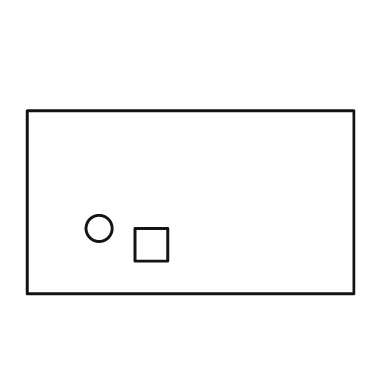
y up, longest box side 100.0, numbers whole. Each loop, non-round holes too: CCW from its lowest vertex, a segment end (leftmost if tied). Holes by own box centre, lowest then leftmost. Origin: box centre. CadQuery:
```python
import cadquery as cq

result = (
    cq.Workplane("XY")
    .moveTo(-50.0, -28.0)
    .lineTo(50.0, -28.0)
    .lineTo(50.0, 28.0)
    .lineTo(-50.0, 28.0)
    .close()
    .moveTo(-17.0, -18.0)
    .lineTo(-7.0, -18.0)
    .lineTo(-7.0, -8.0)
    .lineTo(-17.0, -8.0)
    .close()
    .moveTo(-28.0, -8.0)
    .circle(4.0)
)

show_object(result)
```